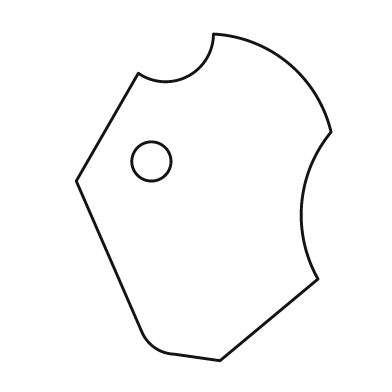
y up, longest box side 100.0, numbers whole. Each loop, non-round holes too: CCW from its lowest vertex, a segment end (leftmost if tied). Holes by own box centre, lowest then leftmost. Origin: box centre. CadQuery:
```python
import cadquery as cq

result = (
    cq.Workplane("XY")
    .moveTo(5.0, -50.0)
    .lineTo(35.0, -25.0)
    .threePointArc((30.0, -2.0), (39.0, 20.0))
    .threePointArc((26.0, 41.0), (3.0, 50.0))
    .threePointArc((-5.0, 37.0), (-20.0, 38.0))
    .lineTo(-39.0, 5.0)
    .lineTo(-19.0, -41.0)
    .threePointArc((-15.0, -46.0), (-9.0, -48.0))
    .close()
    .moveTo(-16.0, 11.0)
    .circle(6.0)
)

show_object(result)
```